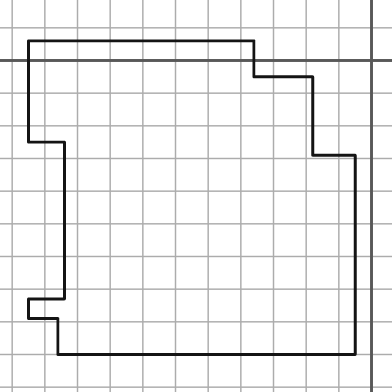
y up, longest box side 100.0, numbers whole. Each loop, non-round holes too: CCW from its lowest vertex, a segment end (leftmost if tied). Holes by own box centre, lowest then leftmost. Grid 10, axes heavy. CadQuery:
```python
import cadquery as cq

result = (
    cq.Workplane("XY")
    .moveTo(-96.0, -90.0)
    .lineTo(-5.0, -90.0)
    .lineTo(-5.0, -29.0)
    .lineTo(-18.0, -29.0)
    .lineTo(-18.0, -5.0)
    .lineTo(-36.0, -5.0)
    .lineTo(-36.0, 6.0)
    .lineTo(-105.0, 6.0)
    .lineTo(-105.0, -25.0)
    .lineTo(-94.0, -25.0)
    .lineTo(-94.0, -73.0)
    .lineTo(-105.0, -73.0)
    .lineTo(-105.0, -79.0)
    .lineTo(-96.0, -79.0)
    .close()
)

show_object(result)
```